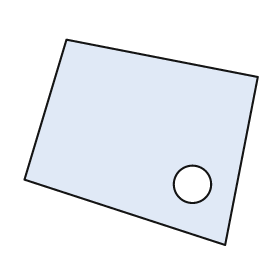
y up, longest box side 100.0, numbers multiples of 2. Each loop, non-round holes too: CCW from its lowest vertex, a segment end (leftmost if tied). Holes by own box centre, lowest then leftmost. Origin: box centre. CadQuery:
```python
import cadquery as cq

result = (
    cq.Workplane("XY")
    .moveTo(36.0, -44.0)
    .lineTo(50.0, 28.0)
    .lineTo(-32.0, 44.0)
    .lineTo(-50.0, -16.0)
    .close()
    .moveTo(22.0, -18.0)
    .circle(8.0)
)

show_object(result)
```